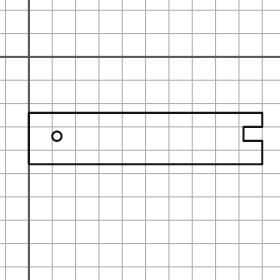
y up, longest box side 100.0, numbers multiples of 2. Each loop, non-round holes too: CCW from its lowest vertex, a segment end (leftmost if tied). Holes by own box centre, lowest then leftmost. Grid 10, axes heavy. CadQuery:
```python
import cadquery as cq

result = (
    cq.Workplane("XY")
    .moveTo(0.0, -46.0)
    .lineTo(100.0, -46.0)
    .lineTo(100.0, -36.0)
    .lineTo(92.0, -36.0)
    .lineTo(92.0, -30.0)
    .lineTo(100.0, -30.0)
    .lineTo(100.0, -24.0)
    .lineTo(0.0, -24.0)
    .close()
    .moveTo(12.0, -34.0)
    .circle(2.0)
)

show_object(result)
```